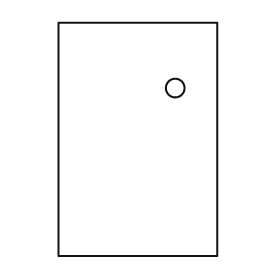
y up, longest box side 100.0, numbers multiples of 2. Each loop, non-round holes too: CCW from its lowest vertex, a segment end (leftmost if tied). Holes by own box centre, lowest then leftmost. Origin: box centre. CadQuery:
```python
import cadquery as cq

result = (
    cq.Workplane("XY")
    .moveTo(-34.0, -50.0)
    .lineTo(34.0, -50.0)
    .lineTo(34.0, 50.0)
    .lineTo(-34.0, 50.0)
    .close()
    .moveTo(16.0, 22.0)
    .circle(4.0)
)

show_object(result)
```